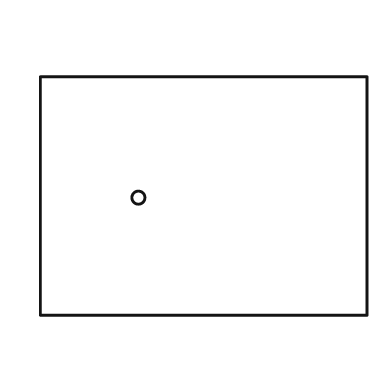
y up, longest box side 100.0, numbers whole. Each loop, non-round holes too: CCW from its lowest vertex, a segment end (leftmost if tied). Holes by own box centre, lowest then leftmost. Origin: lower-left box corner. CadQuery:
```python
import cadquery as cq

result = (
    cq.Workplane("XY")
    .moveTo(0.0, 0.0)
    .lineTo(100.0, 0.0)
    .lineTo(100.0, 73.0)
    .lineTo(0.0, 73.0)
    .close()
    .moveTo(30.0, 36.0)
    .circle(2.0)
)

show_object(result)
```